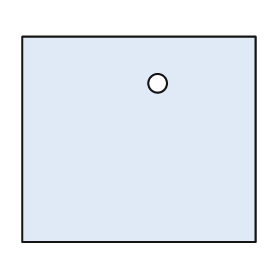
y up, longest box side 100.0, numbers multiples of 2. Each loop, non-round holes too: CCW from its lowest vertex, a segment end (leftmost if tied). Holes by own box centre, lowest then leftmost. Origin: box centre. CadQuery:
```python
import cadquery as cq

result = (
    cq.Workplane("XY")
    .moveTo(-50.0, -44.0)
    .lineTo(50.0, -44.0)
    .lineTo(50.0, 44.0)
    .lineTo(-50.0, 44.0)
    .close()
    .moveTo(8.0, 24.0)
    .circle(4.0)
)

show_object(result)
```